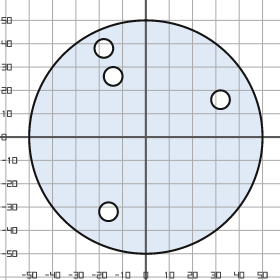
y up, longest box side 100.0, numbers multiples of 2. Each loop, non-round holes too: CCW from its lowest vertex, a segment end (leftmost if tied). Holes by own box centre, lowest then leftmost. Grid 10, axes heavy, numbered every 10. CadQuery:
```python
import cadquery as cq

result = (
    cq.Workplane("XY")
    .moveTo(0.0, 0.0)
    .circle(50.0)
    .moveTo(-16.0, -32.0)
    .circle(4.0)
    .moveTo(32.0, 16.0)
    .circle(4.0)
    .moveTo(-14.0, 26.0)
    .circle(4.0)
    .moveTo(-18.0, 38.0)
    .circle(4.0)
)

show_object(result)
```